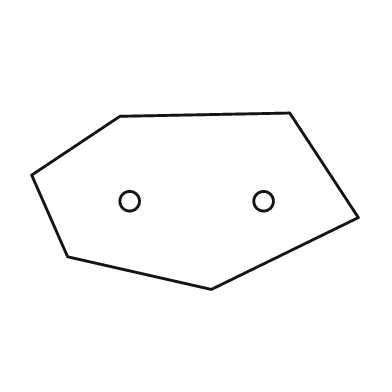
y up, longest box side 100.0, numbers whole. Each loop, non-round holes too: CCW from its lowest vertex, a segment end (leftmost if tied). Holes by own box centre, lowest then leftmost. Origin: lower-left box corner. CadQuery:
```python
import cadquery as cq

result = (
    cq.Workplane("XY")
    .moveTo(55.0, 0.0)
    .lineTo(100.0, 22.0)
    .lineTo(79.0, 54.0)
    .lineTo(27.0, 53.0)
    .lineTo(0.0, 35.0)
    .lineTo(11.0, 10.0)
    .close()
    .moveTo(30.0, 27.0)
    .circle(3.0)
    .moveTo(71.0, 27.0)
    .circle(3.0)
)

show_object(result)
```